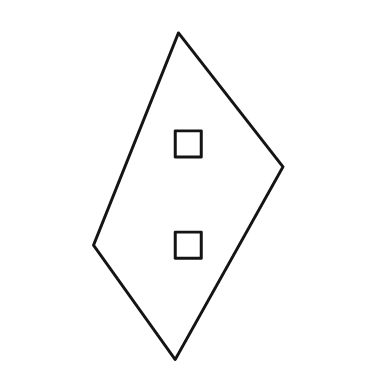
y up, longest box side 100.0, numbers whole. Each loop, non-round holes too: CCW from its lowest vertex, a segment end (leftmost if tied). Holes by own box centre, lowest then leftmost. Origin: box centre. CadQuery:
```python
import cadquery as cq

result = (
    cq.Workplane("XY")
    .moveTo(-4.0, -50.0)
    .lineTo(29.0, 9.0)
    .lineTo(-3.0, 50.0)
    .lineTo(-29.0, -15.0)
    .close()
    .moveTo(-4.0, -19.0)
    .lineTo(4.0, -19.0)
    .lineTo(4.0, -11.0)
    .lineTo(-4.0, -11.0)
    .close()
    .moveTo(-4.0, 12.0)
    .lineTo(4.0, 12.0)
    .lineTo(4.0, 20.0)
    .lineTo(-4.0, 20.0)
    .close()
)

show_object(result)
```